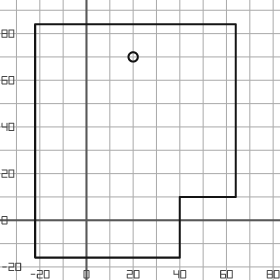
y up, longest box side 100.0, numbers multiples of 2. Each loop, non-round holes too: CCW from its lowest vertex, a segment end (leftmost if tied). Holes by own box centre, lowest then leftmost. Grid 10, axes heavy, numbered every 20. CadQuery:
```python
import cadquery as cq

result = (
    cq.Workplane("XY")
    .moveTo(-22.0, -16.0)
    .lineTo(40.0, -16.0)
    .lineTo(40.0, 10.0)
    .lineTo(64.0, 10.0)
    .lineTo(64.0, 84.0)
    .lineTo(-22.0, 84.0)
    .close()
    .moveTo(20.0, 70.0)
    .circle(2.0)
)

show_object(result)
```